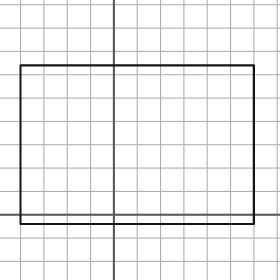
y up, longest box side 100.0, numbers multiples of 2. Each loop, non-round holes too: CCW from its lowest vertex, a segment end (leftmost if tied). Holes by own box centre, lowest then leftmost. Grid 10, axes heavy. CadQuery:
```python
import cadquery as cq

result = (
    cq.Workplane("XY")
    .moveTo(-40.0, -4.0)
    .lineTo(60.0, -4.0)
    .lineTo(60.0, 64.0)
    .lineTo(-40.0, 64.0)
    .close()
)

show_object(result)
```